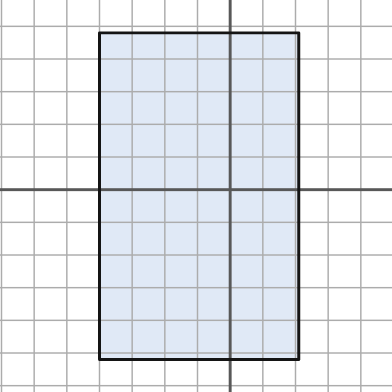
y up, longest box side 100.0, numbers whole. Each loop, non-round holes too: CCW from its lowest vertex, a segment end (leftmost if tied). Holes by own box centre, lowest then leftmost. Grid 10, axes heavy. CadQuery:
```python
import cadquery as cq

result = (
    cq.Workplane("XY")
    .moveTo(-40.0, -52.0)
    .lineTo(21.0, -52.0)
    .lineTo(21.0, 48.0)
    .lineTo(-40.0, 48.0)
    .close()
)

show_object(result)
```